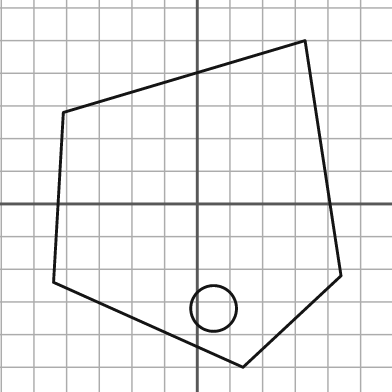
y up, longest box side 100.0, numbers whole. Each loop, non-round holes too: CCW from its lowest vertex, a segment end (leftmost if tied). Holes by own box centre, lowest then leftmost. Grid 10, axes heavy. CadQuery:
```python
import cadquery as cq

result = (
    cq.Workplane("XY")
    .moveTo(14.0, -50.0)
    .lineTo(44.0, -22.0)
    .lineTo(33.0, 50.0)
    .lineTo(-41.0, 28.0)
    .lineTo(-44.0, -24.0)
    .close()
    .moveTo(5.0, -32.0)
    .circle(7.0)
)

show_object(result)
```